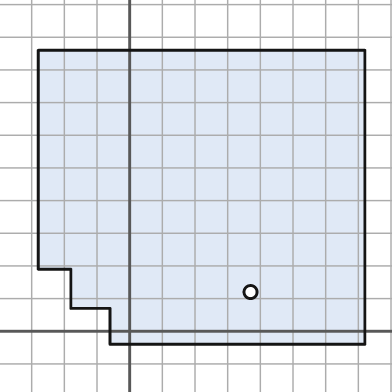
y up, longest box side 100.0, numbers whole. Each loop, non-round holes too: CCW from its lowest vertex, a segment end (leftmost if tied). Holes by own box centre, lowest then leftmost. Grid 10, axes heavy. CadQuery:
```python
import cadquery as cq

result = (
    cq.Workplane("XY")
    .moveTo(-6.0, -4.0)
    .lineTo(72.0, -4.0)
    .lineTo(72.0, 86.0)
    .lineTo(-28.0, 86.0)
    .lineTo(-28.0, 19.0)
    .lineTo(-18.0, 19.0)
    .lineTo(-18.0, 7.0)
    .lineTo(-6.0, 7.0)
    .close()
    .moveTo(37.0, 12.0)
    .circle(2.0)
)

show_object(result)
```